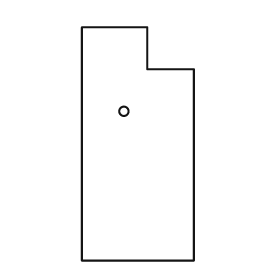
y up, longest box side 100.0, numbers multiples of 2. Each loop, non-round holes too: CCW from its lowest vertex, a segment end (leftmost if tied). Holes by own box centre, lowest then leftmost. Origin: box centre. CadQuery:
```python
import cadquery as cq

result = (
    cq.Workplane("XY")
    .moveTo(-24.0, -50.0)
    .lineTo(24.0, -50.0)
    .lineTo(24.0, 32.0)
    .lineTo(4.0, 32.0)
    .lineTo(4.0, 50.0)
    .lineTo(-24.0, 50.0)
    .close()
    .moveTo(-6.0, 14.0)
    .circle(2.0)
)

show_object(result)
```